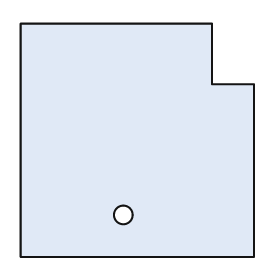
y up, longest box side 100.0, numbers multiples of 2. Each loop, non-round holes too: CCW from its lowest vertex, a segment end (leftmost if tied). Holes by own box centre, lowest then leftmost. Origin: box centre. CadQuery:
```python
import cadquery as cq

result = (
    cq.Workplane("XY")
    .moveTo(-50.0, -50.0)
    .lineTo(50.0, -50.0)
    .lineTo(50.0, 24.0)
    .lineTo(32.0, 24.0)
    .lineTo(32.0, 50.0)
    .lineTo(-50.0, 50.0)
    .close()
    .moveTo(-6.0, -32.0)
    .circle(4.0)
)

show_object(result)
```